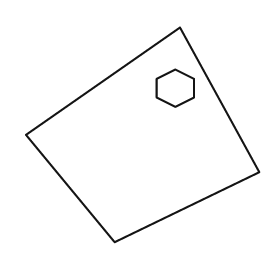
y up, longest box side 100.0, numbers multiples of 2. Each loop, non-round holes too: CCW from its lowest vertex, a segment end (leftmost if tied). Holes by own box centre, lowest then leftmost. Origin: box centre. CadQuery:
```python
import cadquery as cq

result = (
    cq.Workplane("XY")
    .moveTo(-12.0, -46.0)
    .lineTo(50.0, -16.0)
    .lineTo(16.0, 46.0)
    .lineTo(-50.0, 0.0)
    .close()
    .moveTo(14.0, 12.0)
    .lineTo(22.0, 16.0)
    .lineTo(22.0, 24.0)
    .lineTo(14.0, 28.0)
    .lineTo(6.0, 24.0)
    .lineTo(6.0, 16.0)
    .close()
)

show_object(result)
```